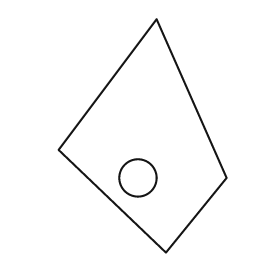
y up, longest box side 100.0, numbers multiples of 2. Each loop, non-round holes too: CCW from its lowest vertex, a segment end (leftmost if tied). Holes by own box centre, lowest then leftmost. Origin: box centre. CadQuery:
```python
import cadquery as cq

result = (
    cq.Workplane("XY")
    .moveTo(10.0, -50.0)
    .lineTo(36.0, -18.0)
    .lineTo(6.0, 50.0)
    .lineTo(-36.0, -6.0)
    .close()
    .moveTo(-2.0, -18.0)
    .circle(8.0)
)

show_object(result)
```